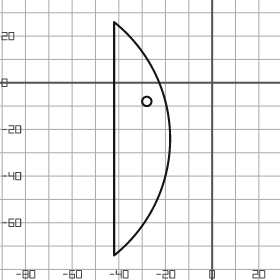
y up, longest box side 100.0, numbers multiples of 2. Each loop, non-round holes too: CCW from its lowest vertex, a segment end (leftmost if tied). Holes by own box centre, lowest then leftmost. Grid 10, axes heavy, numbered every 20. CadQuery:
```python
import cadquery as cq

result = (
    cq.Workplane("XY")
    .moveTo(-42.0, -74.0)
    .threePointArc((-18.0, -24.0), (-42.0, 26.0))
    .close()
    .moveTo(-28.0, -8.0)
    .circle(2.0)
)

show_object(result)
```